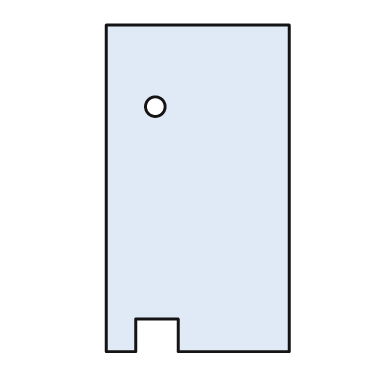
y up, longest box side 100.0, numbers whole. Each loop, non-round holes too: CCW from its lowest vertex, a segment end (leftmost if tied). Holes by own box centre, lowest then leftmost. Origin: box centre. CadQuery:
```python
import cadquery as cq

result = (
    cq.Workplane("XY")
    .moveTo(-28.0, -50.0)
    .lineTo(-19.0, -50.0)
    .lineTo(-19.0, -40.0)
    .lineTo(-6.0, -40.0)
    .lineTo(-6.0, -50.0)
    .lineTo(28.0, -50.0)
    .lineTo(28.0, 50.0)
    .lineTo(-28.0, 50.0)
    .close()
    .moveTo(-13.0, 25.0)
    .circle(3.0)
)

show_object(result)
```